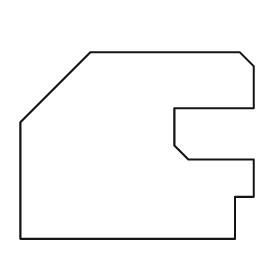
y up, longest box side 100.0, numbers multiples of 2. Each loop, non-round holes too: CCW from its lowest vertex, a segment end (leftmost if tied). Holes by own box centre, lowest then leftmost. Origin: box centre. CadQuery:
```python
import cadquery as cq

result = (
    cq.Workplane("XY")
    .moveTo(-50.0, -40.0)
    .lineTo(42.0, -40.0)
    .lineTo(42.0, -22.0)
    .lineTo(50.0, -22.0)
    .lineTo(50.0, -6.0)
    .lineTo(22.0, -6.0)
    .lineTo(16.0, 0.0)
    .lineTo(16.0, 16.0)
    .lineTo(50.0, 16.0)
    .lineTo(50.0, 34.0)
    .lineTo(44.0, 40.0)
    .lineTo(-20.0, 40.0)
    .lineTo(-50.0, 10.0)
    .close()
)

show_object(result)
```